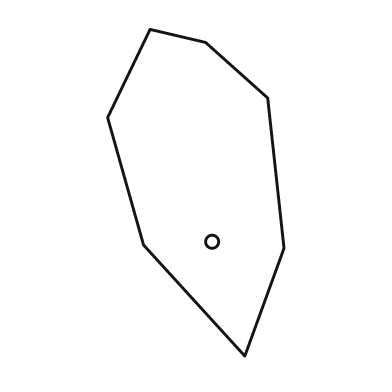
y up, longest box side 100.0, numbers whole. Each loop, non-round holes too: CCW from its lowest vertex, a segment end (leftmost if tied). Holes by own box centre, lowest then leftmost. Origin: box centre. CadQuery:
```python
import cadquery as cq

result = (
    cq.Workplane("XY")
    .moveTo(15.0, -50.0)
    .lineTo(27.0, -17.0)
    .lineTo(22.0, 29.0)
    .lineTo(3.0, 46.0)
    .lineTo(-14.0, 50.0)
    .lineTo(-27.0, 23.0)
    .lineTo(-16.0, -16.0)
    .close()
    .moveTo(5.0, -15.0)
    .circle(2.0)
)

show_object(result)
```